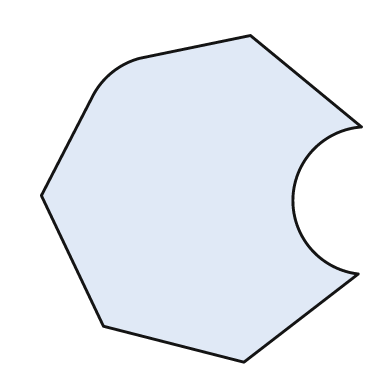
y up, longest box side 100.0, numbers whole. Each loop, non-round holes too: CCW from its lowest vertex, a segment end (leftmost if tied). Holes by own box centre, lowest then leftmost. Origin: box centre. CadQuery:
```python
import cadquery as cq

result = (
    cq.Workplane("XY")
    .moveTo(13.0, -50.0)
    .lineTo(48.0, -23.0)
    .threePointArc((28.0, 0.0), (49.0, 22.0))
    .lineTo(15.0, 50.0)
    .lineTo(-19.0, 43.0)
    .threePointArc((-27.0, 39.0), (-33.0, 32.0))
    .lineTo(-49.0, 1.0)
    .lineTo(-30.0, -39.0)
    .close()
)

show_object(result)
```